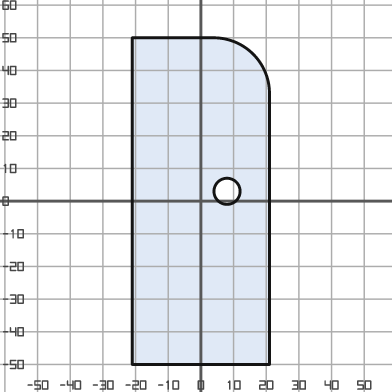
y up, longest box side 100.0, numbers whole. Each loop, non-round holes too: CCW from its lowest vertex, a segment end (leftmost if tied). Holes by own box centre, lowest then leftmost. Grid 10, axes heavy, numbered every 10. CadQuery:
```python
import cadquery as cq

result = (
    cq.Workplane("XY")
    .moveTo(-21.0, -50.0)
    .lineTo(21.0, -50.0)
    .lineTo(21.0, 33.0)
    .threePointArc((16.0, 45.0), (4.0, 50.0))
    .lineTo(-21.0, 50.0)
    .close()
    .moveTo(8.0, 3.0)
    .circle(4.0)
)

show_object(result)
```